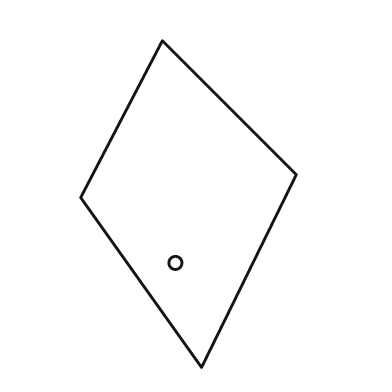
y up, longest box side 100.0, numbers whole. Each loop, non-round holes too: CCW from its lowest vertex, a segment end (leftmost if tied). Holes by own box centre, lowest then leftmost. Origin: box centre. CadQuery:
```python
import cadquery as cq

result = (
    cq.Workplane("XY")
    .moveTo(4.0, -50.0)
    .lineTo(33.0, 9.0)
    .lineTo(-8.0, 50.0)
    .lineTo(-33.0, 2.0)
    .close()
    .moveTo(-4.0, -18.0)
    .circle(2.0)
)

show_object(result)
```